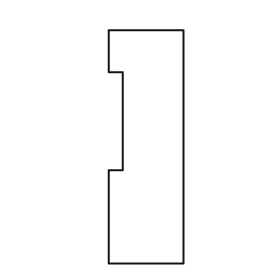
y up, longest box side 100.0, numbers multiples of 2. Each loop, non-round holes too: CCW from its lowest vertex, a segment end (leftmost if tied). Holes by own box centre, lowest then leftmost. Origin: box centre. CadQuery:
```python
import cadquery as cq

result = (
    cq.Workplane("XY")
    .moveTo(-16.0, -50.0)
    .lineTo(16.0, -50.0)
    .lineTo(16.0, 50.0)
    .lineTo(-16.0, 50.0)
    .lineTo(-16.0, 32.0)
    .lineTo(-10.0, 32.0)
    .lineTo(-10.0, -10.0)
    .lineTo(-16.0, -10.0)
    .close()
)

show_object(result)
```